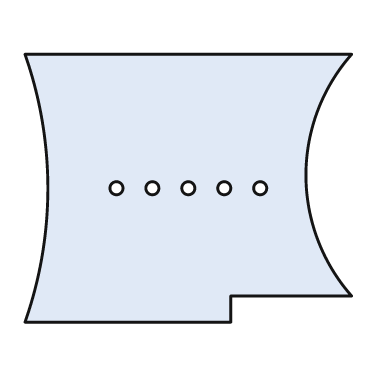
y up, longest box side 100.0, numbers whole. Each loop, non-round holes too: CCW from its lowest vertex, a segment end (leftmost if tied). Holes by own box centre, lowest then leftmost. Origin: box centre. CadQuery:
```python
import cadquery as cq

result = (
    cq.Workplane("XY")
    .moveTo(-50.0, -41.0)
    .lineTo(13.0, -41.0)
    .lineTo(13.0, -33.0)
    .lineTo(50.0, -33.0)
    .threePointArc((36.0, 4.0), (50.0, 41.0))
    .lineTo(-50.0, 41.0)
    .threePointArc((-43.0, 0.0), (-50.0, -41.0))
    .close()
    .moveTo(-22.0, 0.0)
    .circle(2.0)
    .moveTo(-11.0, 0.0)
    .circle(2.0)
    .moveTo(0.0, 0.0)
    .circle(2.0)
    .moveTo(11.0, 0.0)
    .circle(2.0)
    .moveTo(22.0, 0.0)
    .circle(2.0)
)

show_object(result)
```